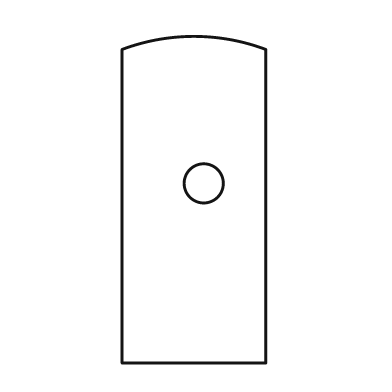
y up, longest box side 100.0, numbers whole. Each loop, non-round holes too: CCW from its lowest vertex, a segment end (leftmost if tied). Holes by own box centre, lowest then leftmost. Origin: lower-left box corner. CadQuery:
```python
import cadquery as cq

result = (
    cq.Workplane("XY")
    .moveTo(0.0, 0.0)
    .lineTo(44.0, 0.0)
    .lineTo(44.0, 96.0)
    .threePointArc((22.0, 100.0), (0.0, 96.0))
    .close()
    .moveTo(25.0, 55.0)
    .circle(6.0)
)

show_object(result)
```